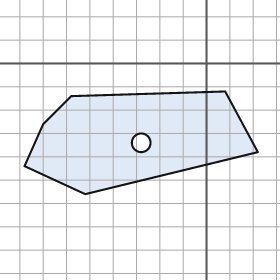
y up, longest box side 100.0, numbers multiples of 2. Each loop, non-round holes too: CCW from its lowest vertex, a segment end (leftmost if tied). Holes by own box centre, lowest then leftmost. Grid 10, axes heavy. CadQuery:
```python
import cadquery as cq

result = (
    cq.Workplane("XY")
    .moveTo(-52.0, -56.0)
    .lineTo(22.0, -38.0)
    .lineTo(8.0, -12.0)
    .lineTo(-58.0, -14.0)
    .lineTo(-70.0, -26.0)
    .lineTo(-78.0, -44.0)
    .close()
    .moveTo(-28.0, -34.0)
    .circle(4.0)
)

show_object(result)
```